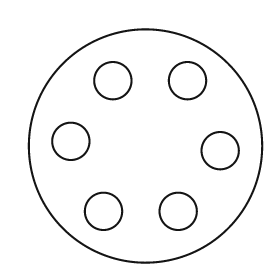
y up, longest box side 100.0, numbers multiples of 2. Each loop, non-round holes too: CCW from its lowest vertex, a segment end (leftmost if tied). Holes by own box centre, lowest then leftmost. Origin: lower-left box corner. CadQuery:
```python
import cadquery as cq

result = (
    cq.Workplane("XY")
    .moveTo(50.0, 50.0)
    .circle(50.0)
    .moveTo(32.0, 22.0)
    .circle(8.0)
    .moveTo(64.0, 22.0)
    .circle(8.0)
    .moveTo(82.0, 48.0)
    .circle(8.0)
    .moveTo(18.0, 52.0)
    .circle(8.0)
    .moveTo(36.0, 78.0)
    .circle(8.0)
    .moveTo(68.0, 78.0)
    .circle(8.0)
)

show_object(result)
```